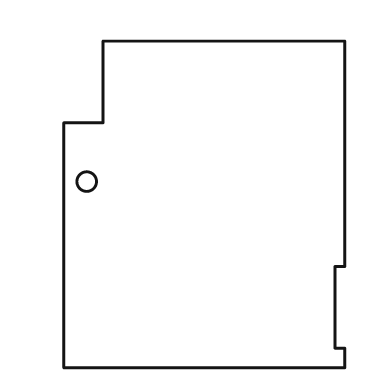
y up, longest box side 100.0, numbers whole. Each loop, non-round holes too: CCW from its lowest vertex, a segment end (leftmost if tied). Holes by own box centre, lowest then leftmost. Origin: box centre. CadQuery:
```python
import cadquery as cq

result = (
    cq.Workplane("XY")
    .moveTo(-43.0, -50.0)
    .lineTo(43.0, -50.0)
    .lineTo(43.0, -44.0)
    .lineTo(40.0, -44.0)
    .lineTo(40.0, -19.0)
    .lineTo(43.0, -19.0)
    .lineTo(43.0, 50.0)
    .lineTo(-31.0, 50.0)
    .lineTo(-31.0, 25.0)
    .lineTo(-43.0, 25.0)
    .close()
    .moveTo(-36.0, 7.0)
    .circle(3.0)
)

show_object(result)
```